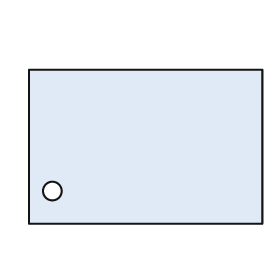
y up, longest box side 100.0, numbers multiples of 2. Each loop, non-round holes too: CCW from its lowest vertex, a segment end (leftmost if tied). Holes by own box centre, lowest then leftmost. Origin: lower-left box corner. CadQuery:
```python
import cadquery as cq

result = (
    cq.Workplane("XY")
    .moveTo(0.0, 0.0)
    .lineTo(100.0, 0.0)
    .lineTo(100.0, 66.0)
    .lineTo(0.0, 66.0)
    .close()
    .moveTo(10.0, 14.0)
    .circle(4.0)
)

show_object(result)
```